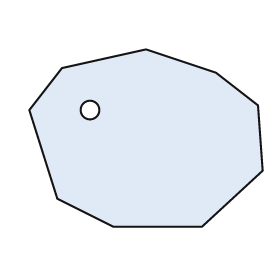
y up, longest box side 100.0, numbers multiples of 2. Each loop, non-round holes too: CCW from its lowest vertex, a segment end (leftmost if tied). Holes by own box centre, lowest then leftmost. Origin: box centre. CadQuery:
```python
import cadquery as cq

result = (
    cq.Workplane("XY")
    .moveTo(-14.0, -38.0)
    .lineTo(24.0, -38.0)
    .lineTo(50.0, -14.0)
    .lineTo(48.0, 14.0)
    .lineTo(30.0, 28.0)
    .lineTo(0.0, 38.0)
    .lineTo(-36.0, 30.0)
    .lineTo(-50.0, 12.0)
    .lineTo(-38.0, -26.0)
    .close()
    .moveTo(-24.0, 12.0)
    .circle(4.0)
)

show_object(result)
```